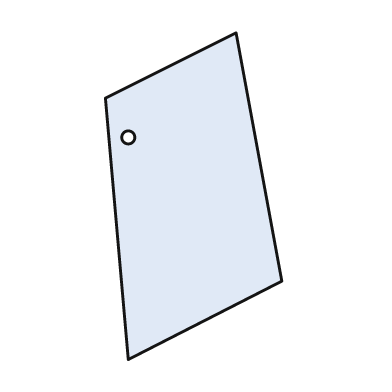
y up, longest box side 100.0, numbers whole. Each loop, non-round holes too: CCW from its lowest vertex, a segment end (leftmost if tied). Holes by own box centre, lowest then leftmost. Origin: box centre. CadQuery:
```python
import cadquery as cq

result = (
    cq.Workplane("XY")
    .moveTo(-20.0, -50.0)
    .lineTo(27.0, -26.0)
    .lineTo(13.0, 50.0)
    .lineTo(-27.0, 30.0)
    .close()
    .moveTo(-20.0, 18.0)
    .circle(2.0)
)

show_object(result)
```